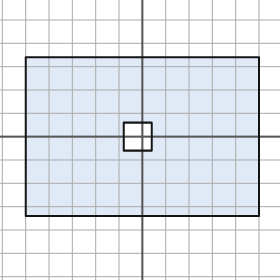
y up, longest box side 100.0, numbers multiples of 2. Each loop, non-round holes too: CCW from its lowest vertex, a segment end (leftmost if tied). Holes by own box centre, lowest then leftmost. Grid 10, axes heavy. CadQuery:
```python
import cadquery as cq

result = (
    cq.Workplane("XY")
    .moveTo(-50.0, -34.0)
    .lineTo(50.0, -34.0)
    .lineTo(50.0, 34.0)
    .lineTo(-50.0, 34.0)
    .close()
    .moveTo(-8.0, -6.0)
    .lineTo(4.0, -6.0)
    .lineTo(4.0, 6.0)
    .lineTo(-8.0, 6.0)
    .close()
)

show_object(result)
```